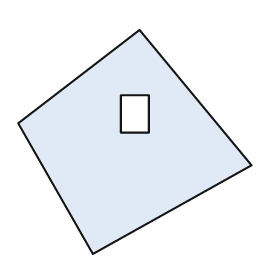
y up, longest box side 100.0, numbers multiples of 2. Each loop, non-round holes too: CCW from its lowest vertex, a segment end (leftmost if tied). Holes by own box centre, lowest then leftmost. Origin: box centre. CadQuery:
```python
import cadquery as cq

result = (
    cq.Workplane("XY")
    .moveTo(-18.0, -48.0)
    .lineTo(50.0, -10.0)
    .lineTo(2.0, 48.0)
    .lineTo(-50.0, 8.0)
    .close()
    .moveTo(-6.0, 4.0)
    .lineTo(6.0, 4.0)
    .lineTo(6.0, 20.0)
    .lineTo(-6.0, 20.0)
    .close()
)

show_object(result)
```